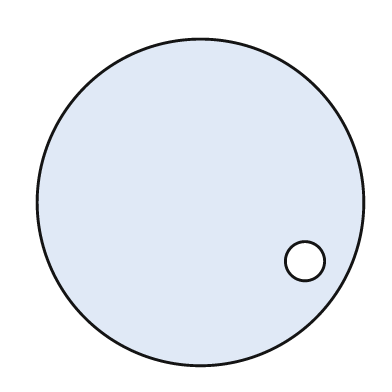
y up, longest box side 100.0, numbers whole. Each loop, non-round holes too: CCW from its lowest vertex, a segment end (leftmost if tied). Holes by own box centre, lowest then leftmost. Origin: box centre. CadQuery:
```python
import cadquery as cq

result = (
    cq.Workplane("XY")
    .moveTo(0.0, 0.0)
    .circle(50.0)
    .moveTo(32.0, -18.0)
    .circle(6.0)
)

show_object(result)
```